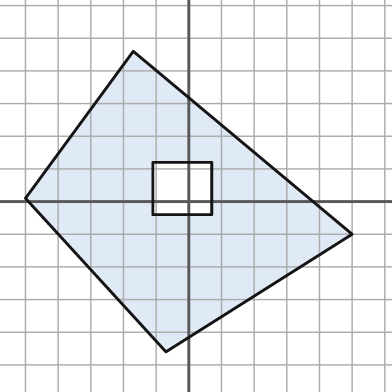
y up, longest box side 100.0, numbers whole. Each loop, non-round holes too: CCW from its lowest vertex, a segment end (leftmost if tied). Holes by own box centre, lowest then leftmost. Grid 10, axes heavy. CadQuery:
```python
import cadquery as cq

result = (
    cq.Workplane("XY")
    .moveTo(-7.0, -46.0)
    .lineTo(50.0, -10.0)
    .lineTo(-17.0, 46.0)
    .lineTo(-50.0, 1.0)
    .close()
    .moveTo(-11.0, -4.0)
    .lineTo(7.0, -4.0)
    .lineTo(7.0, 12.0)
    .lineTo(-11.0, 12.0)
    .close()
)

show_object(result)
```